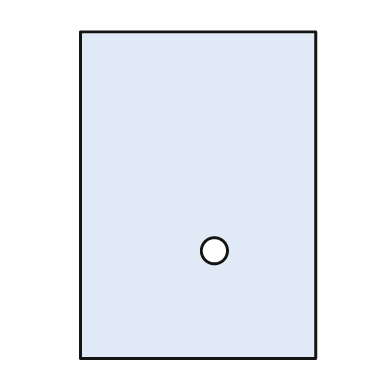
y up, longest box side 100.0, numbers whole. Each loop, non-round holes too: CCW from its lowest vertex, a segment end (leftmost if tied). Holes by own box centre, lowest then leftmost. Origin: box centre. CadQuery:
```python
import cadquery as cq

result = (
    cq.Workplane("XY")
    .moveTo(-36.0, -50.0)
    .lineTo(36.0, -50.0)
    .lineTo(36.0, 50.0)
    .lineTo(-36.0, 50.0)
    .close()
    .moveTo(5.0, -17.0)
    .circle(4.0)
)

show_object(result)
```